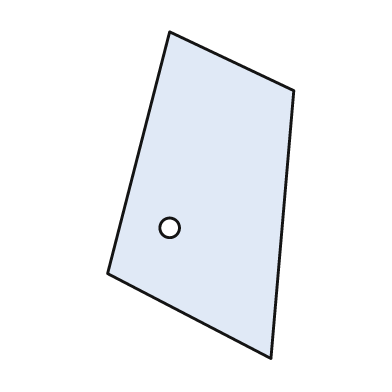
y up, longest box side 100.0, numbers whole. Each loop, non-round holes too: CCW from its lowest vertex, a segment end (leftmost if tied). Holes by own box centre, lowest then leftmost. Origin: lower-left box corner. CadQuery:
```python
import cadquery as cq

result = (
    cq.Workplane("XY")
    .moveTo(50.0, 0.0)
    .lineTo(57.0, 82.0)
    .lineTo(19.0, 100.0)
    .lineTo(0.0, 26.0)
    .close()
    .moveTo(19.0, 40.0)
    .circle(3.0)
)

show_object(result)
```